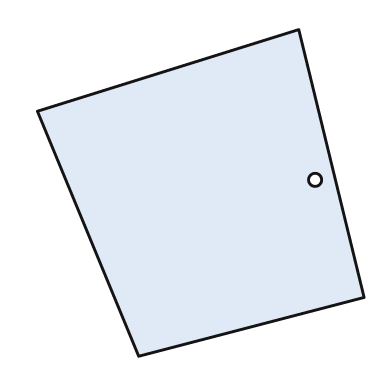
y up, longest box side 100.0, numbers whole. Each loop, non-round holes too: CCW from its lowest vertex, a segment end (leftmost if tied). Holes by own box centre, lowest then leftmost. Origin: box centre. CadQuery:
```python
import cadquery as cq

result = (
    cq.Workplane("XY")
    .moveTo(-19.0, -50.0)
    .lineTo(50.0, -32.0)
    .lineTo(30.0, 50.0)
    .lineTo(-50.0, 25.0)
    .close()
    .moveTo(35.0, 4.0)
    .circle(2.0)
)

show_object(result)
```